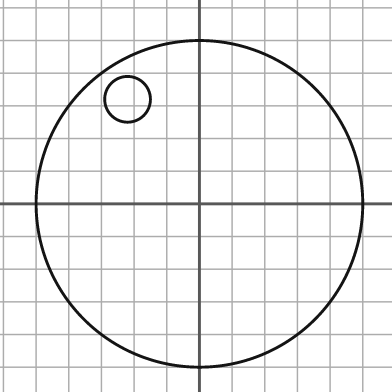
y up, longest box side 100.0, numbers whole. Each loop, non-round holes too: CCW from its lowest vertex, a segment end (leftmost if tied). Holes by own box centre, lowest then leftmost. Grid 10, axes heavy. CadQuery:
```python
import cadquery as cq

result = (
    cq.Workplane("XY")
    .moveTo(0.0, 0.0)
    .circle(50.0)
    .moveTo(-22.0, 32.0)
    .circle(7.0)
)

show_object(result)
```